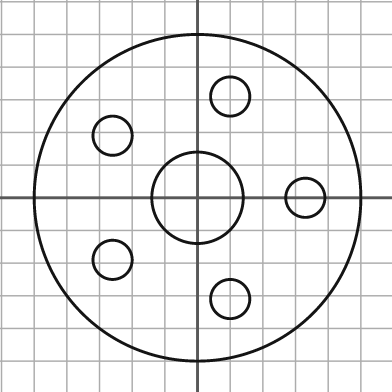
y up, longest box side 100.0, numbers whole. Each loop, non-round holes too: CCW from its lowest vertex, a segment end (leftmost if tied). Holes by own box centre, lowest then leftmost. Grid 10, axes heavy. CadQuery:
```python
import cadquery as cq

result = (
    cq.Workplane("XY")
    .moveTo(0.0, 0.0)
    .circle(50.0)
    .moveTo(10.0, -31.0)
    .circle(6.0)
    .moveTo(-26.0, -19.0)
    .circle(6.0)
    .moveTo(0.0, 0.0)
    .circle(14.0)
    .moveTo(33.0, 0.0)
    .circle(6.0)
    .moveTo(-26.0, 19.0)
    .circle(6.0)
    .moveTo(10.0, 31.0)
    .circle(6.0)
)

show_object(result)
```